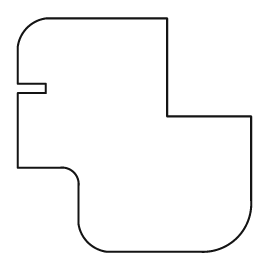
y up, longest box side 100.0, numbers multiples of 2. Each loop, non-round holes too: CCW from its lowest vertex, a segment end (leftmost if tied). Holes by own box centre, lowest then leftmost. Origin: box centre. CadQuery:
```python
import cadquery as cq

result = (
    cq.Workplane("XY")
    .moveTo(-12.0, -50.0)
    .lineTo(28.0, -50.0)
    .threePointArc((44.0, -44.0), (50.0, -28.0))
    .lineTo(50.0, 8.0)
    .lineTo(14.0, 8.0)
    .lineTo(14.0, 50.0)
    .lineTo(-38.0, 50.0)
    .threePointArc((-46.0, 46.0), (-50.0, 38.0))
    .lineTo(-50.0, 22.0)
    .lineTo(-38.0, 22.0)
    .lineTo(-38.0, 18.0)
    .lineTo(-50.0, 18.0)
    .lineTo(-50.0, -14.0)
    .lineTo(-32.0, -14.0)
    .threePointArc((-26.0, -16.0), (-24.0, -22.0))
    .lineTo(-24.0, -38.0)
    .threePointArc((-20.0, -46.0), (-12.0, -50.0))
    .close()
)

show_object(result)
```